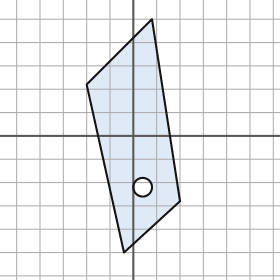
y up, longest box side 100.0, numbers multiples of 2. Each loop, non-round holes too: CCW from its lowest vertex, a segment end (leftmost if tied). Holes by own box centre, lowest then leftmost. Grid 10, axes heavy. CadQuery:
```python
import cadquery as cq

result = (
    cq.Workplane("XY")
    .moveTo(-4.0, -50.0)
    .lineTo(20.0, -28.0)
    .lineTo(8.0, 50.0)
    .lineTo(-20.0, 22.0)
    .close()
    .moveTo(4.0, -22.0)
    .circle(4.0)
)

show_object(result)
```